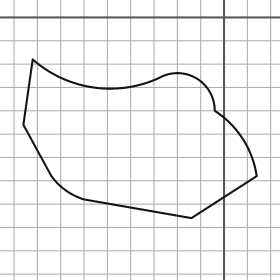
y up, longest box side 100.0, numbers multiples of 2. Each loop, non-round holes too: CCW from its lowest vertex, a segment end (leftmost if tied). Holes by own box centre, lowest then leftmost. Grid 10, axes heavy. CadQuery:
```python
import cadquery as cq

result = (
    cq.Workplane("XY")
    .moveTo(-14.0, -86.0)
    .lineTo(14.0, -68.0)
    .threePointArc((8.0, -52.0), (-4.0, -40.0))
    .threePointArc((-12.0, -26.0), (-28.0, -26.0))
    .threePointArc((-56.0, -30.0), (-82.0, -18.0))
    .lineTo(-86.0, -46.0)
    .lineTo(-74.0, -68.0)
    .threePointArc((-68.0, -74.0), (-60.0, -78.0))
    .close()
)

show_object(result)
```